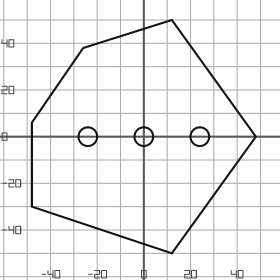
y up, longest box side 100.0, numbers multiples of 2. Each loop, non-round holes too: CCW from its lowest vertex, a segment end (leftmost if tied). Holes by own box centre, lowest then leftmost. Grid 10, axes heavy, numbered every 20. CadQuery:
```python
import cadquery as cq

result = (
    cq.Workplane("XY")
    .moveTo(12.0, -50.0)
    .lineTo(48.0, 0.0)
    .lineTo(12.0, 50.0)
    .lineTo(-26.0, 38.0)
    .lineTo(-48.0, 6.0)
    .lineTo(-48.0, -30.0)
    .close()
    .moveTo(-24.0, 0.0)
    .circle(4.0)
    .moveTo(0.0, 0.0)
    .circle(4.0)
    .moveTo(24.0, 0.0)
    .circle(4.0)
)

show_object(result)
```